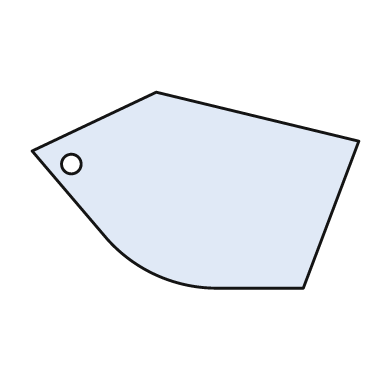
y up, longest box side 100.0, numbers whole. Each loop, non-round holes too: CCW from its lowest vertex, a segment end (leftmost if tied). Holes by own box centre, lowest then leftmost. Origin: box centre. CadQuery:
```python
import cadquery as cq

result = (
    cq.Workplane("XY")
    .moveTo(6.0, -30.0)
    .lineTo(33.0, -30.0)
    .lineTo(50.0, 15.0)
    .lineTo(-12.0, 30.0)
    .lineTo(-50.0, 12.0)
    .lineTo(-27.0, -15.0)
    .threePointArc((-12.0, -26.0), (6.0, -30.0))
    .close()
    .moveTo(-38.0, 8.0)
    .circle(3.0)
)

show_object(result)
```